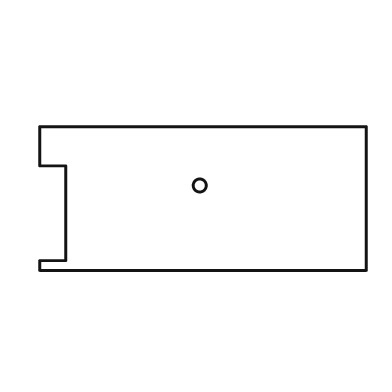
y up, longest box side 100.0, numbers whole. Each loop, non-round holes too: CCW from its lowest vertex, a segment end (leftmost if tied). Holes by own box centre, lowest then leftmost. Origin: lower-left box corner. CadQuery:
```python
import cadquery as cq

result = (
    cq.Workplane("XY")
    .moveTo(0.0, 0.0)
    .lineTo(100.0, 0.0)
    .lineTo(100.0, 44.0)
    .lineTo(0.0, 44.0)
    .lineTo(0.0, 32.0)
    .lineTo(8.0, 32.0)
    .lineTo(8.0, 3.0)
    .lineTo(0.0, 3.0)
    .close()
    .moveTo(49.0, 26.0)
    .circle(2.0)
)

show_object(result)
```